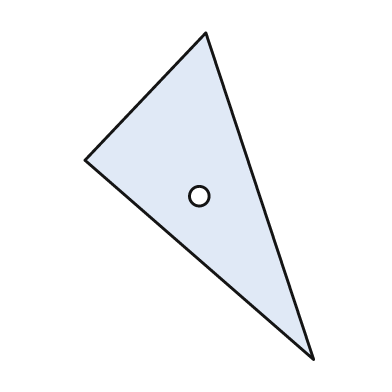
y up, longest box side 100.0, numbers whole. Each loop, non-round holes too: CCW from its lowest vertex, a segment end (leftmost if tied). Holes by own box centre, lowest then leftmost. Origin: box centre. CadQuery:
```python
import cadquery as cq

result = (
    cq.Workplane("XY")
    .moveTo(35.0, -50.0)
    .lineTo(2.0, 50.0)
    .lineTo(-35.0, 11.0)
    .close()
    .moveTo(0.0, 0.0)
    .circle(3.0)
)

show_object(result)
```